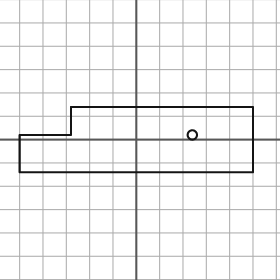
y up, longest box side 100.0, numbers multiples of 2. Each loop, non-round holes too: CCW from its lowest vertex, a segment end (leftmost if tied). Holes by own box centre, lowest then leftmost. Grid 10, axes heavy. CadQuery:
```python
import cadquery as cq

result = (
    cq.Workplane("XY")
    .moveTo(-50.0, -14.0)
    .lineTo(50.0, -14.0)
    .lineTo(50.0, 14.0)
    .lineTo(-28.0, 14.0)
    .lineTo(-28.0, 2.0)
    .lineTo(-50.0, 2.0)
    .close()
    .moveTo(24.0, 2.0)
    .circle(2.0)
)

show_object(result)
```